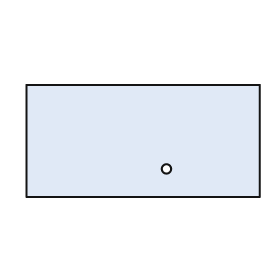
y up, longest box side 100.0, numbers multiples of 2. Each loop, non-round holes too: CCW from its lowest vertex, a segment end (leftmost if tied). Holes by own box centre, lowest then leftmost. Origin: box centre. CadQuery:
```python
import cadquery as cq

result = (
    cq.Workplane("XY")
    .moveTo(-50.0, -24.0)
    .lineTo(50.0, -24.0)
    .lineTo(50.0, 24.0)
    .lineTo(-50.0, 24.0)
    .close()
    .moveTo(10.0, -12.0)
    .circle(2.0)
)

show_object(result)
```